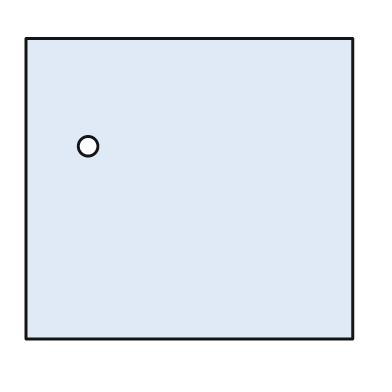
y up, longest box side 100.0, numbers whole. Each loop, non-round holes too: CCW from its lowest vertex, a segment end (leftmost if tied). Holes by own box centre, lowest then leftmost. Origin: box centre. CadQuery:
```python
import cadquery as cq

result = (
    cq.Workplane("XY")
    .moveTo(-50.0, -46.0)
    .lineTo(50.0, -46.0)
    .lineTo(50.0, 46.0)
    .lineTo(-50.0, 46.0)
    .close()
    .moveTo(-31.0, 13.0)
    .circle(3.0)
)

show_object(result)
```